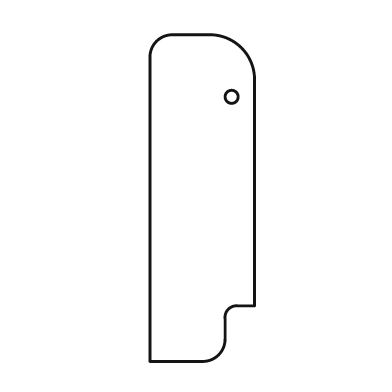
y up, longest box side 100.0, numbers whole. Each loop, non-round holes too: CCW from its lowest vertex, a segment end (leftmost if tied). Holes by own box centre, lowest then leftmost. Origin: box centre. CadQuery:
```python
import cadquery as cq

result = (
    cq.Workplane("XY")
    .moveTo(-16.0, -50.0)
    .lineTo(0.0, -50.0)
    .threePointArc((5.0, -48.0), (7.0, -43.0))
    .lineTo(7.0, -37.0)
    .threePointArc((8.0, -34.0), (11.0, -33.0))
    .lineTo(16.0, -33.0)
    .lineTo(16.0, 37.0)
    .threePointArc((12.0, 46.0), (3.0, 50.0))
    .lineTo(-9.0, 50.0)
    .threePointArc((-14.0, 48.0), (-16.0, 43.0))
    .close()
    .moveTo(9.0, 31.0)
    .circle(2.0)
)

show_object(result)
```